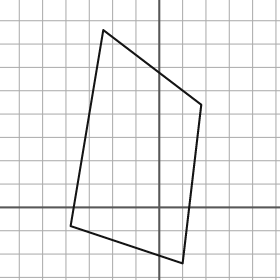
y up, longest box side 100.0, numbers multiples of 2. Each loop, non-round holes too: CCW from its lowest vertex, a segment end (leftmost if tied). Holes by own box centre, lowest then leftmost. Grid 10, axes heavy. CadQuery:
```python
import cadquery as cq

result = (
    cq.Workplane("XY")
    .moveTo(10.0, -24.0)
    .lineTo(18.0, 44.0)
    .lineTo(-24.0, 76.0)
    .lineTo(-38.0, -8.0)
    .close()
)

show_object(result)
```